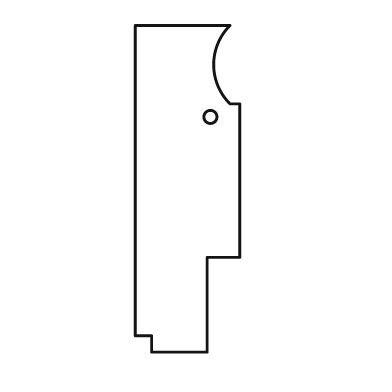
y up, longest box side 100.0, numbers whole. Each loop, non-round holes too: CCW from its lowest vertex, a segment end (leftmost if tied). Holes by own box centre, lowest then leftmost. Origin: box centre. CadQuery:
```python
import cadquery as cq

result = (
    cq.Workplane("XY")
    .moveTo(-11.0, -50.0)
    .lineTo(6.0, -50.0)
    .lineTo(6.0, -21.0)
    .lineTo(16.0, -21.0)
    .lineTo(16.0, 26.0)
    .lineTo(13.0, 26.0)
    .threePointArc((8.0, 38.0), (13.0, 50.0))
    .lineTo(-16.0, 50.0)
    .lineTo(-16.0, -45.0)
    .lineTo(-11.0, -45.0)
    .close()
    .moveTo(7.0, 22.0)
    .circle(2.0)
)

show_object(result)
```